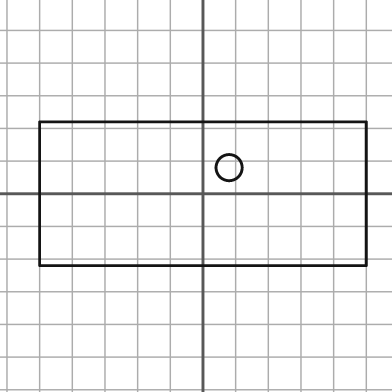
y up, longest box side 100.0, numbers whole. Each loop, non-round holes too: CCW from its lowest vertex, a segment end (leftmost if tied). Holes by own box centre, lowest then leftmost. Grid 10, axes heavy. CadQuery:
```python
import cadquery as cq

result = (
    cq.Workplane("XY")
    .moveTo(-50.0, -22.0)
    .lineTo(50.0, -22.0)
    .lineTo(50.0, 22.0)
    .lineTo(-50.0, 22.0)
    .close()
    .moveTo(8.0, 8.0)
    .circle(4.0)
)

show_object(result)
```